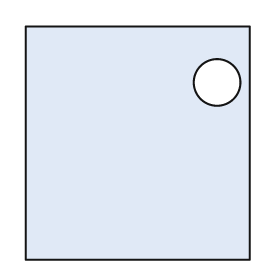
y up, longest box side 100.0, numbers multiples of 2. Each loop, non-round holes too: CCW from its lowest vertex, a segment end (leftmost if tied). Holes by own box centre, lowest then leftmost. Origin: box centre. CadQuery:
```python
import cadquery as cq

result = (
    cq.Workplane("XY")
    .moveTo(-48.0, -50.0)
    .lineTo(48.0, -50.0)
    .lineTo(48.0, 50.0)
    .lineTo(-48.0, 50.0)
    .close()
    .moveTo(34.0, 26.0)
    .circle(10.0)
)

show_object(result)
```